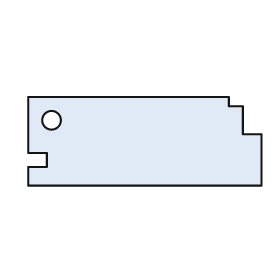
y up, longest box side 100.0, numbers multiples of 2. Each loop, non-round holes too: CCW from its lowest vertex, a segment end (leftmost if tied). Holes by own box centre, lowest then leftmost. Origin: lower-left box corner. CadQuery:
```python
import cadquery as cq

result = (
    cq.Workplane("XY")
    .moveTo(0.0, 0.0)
    .lineTo(100.0, 0.0)
    .lineTo(100.0, 22.0)
    .lineTo(92.0, 22.0)
    .lineTo(92.0, 34.0)
    .lineTo(86.0, 34.0)
    .lineTo(86.0, 38.0)
    .lineTo(0.0, 38.0)
    .lineTo(0.0, 14.0)
    .lineTo(8.0, 14.0)
    .lineTo(8.0, 8.0)
    .lineTo(0.0, 8.0)
    .close()
    .moveTo(10.0, 28.0)
    .circle(4.0)
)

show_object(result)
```